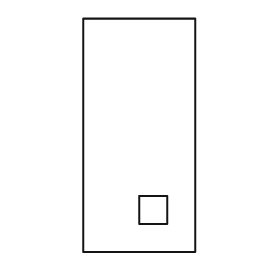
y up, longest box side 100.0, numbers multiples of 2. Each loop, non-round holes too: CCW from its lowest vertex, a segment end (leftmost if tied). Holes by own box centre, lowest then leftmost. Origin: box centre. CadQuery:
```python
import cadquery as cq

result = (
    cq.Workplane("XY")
    .moveTo(-24.0, -50.0)
    .lineTo(24.0, -50.0)
    .lineTo(24.0, 50.0)
    .lineTo(-24.0, 50.0)
    .close()
    .moveTo(0.0, -38.0)
    .lineTo(12.0, -38.0)
    .lineTo(12.0, -26.0)
    .lineTo(0.0, -26.0)
    .close()
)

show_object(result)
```